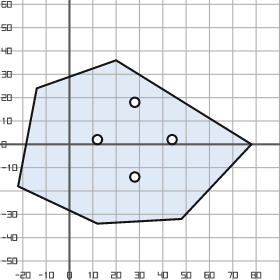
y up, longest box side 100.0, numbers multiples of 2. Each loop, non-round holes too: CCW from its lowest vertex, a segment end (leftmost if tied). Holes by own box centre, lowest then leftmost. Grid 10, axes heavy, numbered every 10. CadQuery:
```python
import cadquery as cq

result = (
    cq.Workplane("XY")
    .moveTo(12.0, -34.0)
    .lineTo(48.0, -32.0)
    .lineTo(78.0, 0.0)
    .lineTo(20.0, 36.0)
    .lineTo(-14.0, 24.0)
    .lineTo(-22.0, -18.0)
    .close()
    .moveTo(28.0, -14.0)
    .circle(2.0)
    .moveTo(12.0, 2.0)
    .circle(2.0)
    .moveTo(44.0, 2.0)
    .circle(2.0)
    .moveTo(28.0, 18.0)
    .circle(2.0)
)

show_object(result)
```